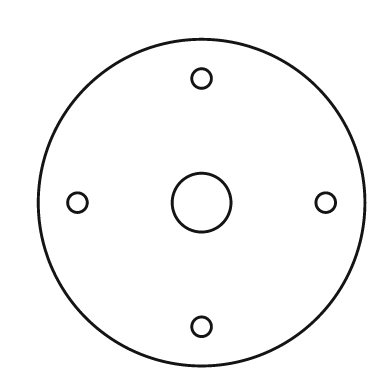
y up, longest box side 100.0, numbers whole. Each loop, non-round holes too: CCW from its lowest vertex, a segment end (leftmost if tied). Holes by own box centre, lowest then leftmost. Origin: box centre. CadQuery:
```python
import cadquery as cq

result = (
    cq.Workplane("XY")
    .moveTo(0.0, 0.0)
    .circle(50.0)
    .moveTo(0.0, -38.0)
    .circle(3.0)
    .moveTo(-38.0, 0.0)
    .circle(3.0)
    .moveTo(0.0, 0.0)
    .circle(9.0)
    .moveTo(38.0, 0.0)
    .circle(3.0)
    .moveTo(0.0, 38.0)
    .circle(3.0)
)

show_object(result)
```